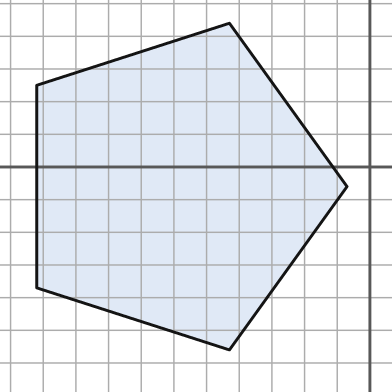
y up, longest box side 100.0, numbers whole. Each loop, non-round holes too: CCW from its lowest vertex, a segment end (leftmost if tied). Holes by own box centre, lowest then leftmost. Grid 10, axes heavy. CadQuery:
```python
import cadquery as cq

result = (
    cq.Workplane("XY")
    .moveTo(-43.0, -56.0)
    .lineTo(-7.0, -6.0)
    .lineTo(-43.0, 44.0)
    .lineTo(-102.0, 25.0)
    .lineTo(-102.0, -37.0)
    .close()
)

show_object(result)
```